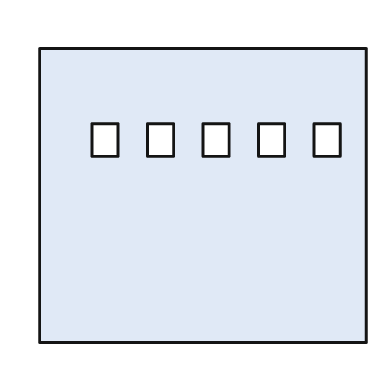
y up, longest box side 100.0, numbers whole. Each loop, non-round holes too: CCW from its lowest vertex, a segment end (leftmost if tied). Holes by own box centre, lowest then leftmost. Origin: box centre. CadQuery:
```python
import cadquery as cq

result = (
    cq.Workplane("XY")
    .moveTo(-50.0, -45.0)
    .lineTo(50.0, -45.0)
    .lineTo(50.0, 45.0)
    .lineTo(-50.0, 45.0)
    .close()
    .moveTo(-34.0, 12.0)
    .lineTo(-26.0, 12.0)
    .lineTo(-26.0, 22.0)
    .lineTo(-34.0, 22.0)
    .close()
    .moveTo(-17.0, 12.0)
    .lineTo(-9.0, 12.0)
    .lineTo(-9.0, 22.0)
    .lineTo(-17.0, 22.0)
    .close()
    .moveTo(0.0, 12.0)
    .lineTo(8.0, 12.0)
    .lineTo(8.0, 22.0)
    .lineTo(0.0, 22.0)
    .close()
    .moveTo(17.0, 12.0)
    .lineTo(25.0, 12.0)
    .lineTo(25.0, 22.0)
    .lineTo(17.0, 22.0)
    .close()
    .moveTo(34.0, 12.0)
    .lineTo(42.0, 12.0)
    .lineTo(42.0, 22.0)
    .lineTo(34.0, 22.0)
    .close()
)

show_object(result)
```